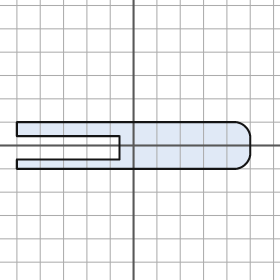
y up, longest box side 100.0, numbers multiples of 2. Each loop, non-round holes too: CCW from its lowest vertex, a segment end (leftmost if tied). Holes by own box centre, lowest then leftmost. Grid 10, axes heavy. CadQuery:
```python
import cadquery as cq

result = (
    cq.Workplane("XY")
    .moveTo(-50.0, -10.0)
    .lineTo(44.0, -10.0)
    .threePointArc((48.0, -8.0), (50.0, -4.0))
    .lineTo(50.0, 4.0)
    .threePointArc((48.0, 8.0), (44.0, 10.0))
    .lineTo(-50.0, 10.0)
    .lineTo(-50.0, 4.0)
    .lineTo(-6.0, 4.0)
    .lineTo(-6.0, -6.0)
    .lineTo(-50.0, -6.0)
    .close()
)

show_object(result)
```